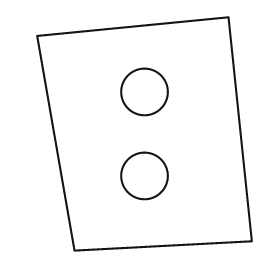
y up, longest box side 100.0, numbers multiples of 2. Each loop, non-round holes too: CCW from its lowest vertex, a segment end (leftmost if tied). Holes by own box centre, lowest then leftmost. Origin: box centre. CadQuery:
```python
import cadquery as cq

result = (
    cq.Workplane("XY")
    .moveTo(-30.0, -50.0)
    .lineTo(46.0, -46.0)
    .lineTo(36.0, 50.0)
    .lineTo(-46.0, 42.0)
    .close()
    .moveTo(0.0, -18.0)
    .circle(10.0)
    .moveTo(0.0, 18.0)
    .circle(10.0)
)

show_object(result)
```